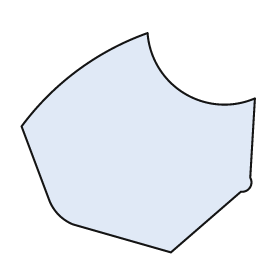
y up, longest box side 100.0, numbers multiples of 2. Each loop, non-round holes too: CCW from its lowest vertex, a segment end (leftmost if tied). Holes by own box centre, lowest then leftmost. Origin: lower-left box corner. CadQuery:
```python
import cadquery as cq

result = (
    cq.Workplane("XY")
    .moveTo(64.0, 0.0)
    .lineTo(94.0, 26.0)
    .threePointArc((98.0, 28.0), (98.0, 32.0))
    .lineTo(100.0, 66.0)
    .threePointArc((70.0, 68.0), (54.0, 94.0))
    .threePointArc((24.0, 78.0), (0.0, 54.0))
    .lineTo(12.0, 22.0)
    .threePointArc((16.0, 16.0), (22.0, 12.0))
    .close()
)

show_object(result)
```